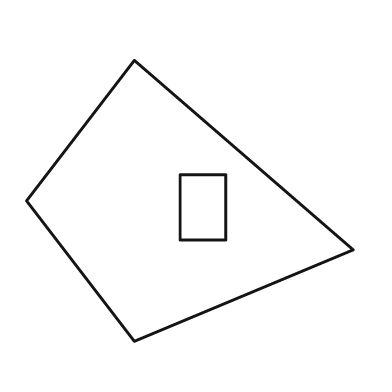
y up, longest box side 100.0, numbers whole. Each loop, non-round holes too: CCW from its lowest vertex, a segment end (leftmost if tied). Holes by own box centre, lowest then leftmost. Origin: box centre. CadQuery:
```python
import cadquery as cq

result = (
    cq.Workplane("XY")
    .moveTo(-17.0, -43.0)
    .lineTo(50.0, -15.0)
    .lineTo(-17.0, 43.0)
    .lineTo(-50.0, 0.0)
    .close()
    .moveTo(-3.0, -12.0)
    .lineTo(11.0, -12.0)
    .lineTo(11.0, 8.0)
    .lineTo(-3.0, 8.0)
    .close()
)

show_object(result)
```